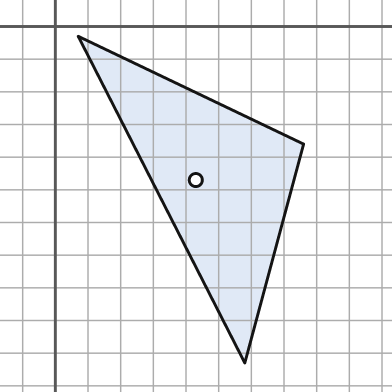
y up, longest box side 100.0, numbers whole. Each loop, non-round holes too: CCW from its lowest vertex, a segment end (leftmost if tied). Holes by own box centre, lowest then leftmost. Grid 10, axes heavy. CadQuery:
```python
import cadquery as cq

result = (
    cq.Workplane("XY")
    .moveTo(58.0, -103.0)
    .lineTo(76.0, -36.0)
    .lineTo(7.0, -3.0)
    .close()
    .moveTo(43.0, -47.0)
    .circle(2.0)
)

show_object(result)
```